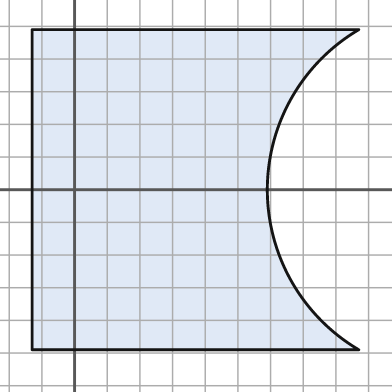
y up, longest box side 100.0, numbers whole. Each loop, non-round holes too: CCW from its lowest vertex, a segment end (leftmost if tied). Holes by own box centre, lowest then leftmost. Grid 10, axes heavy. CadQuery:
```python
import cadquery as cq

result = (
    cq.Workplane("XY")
    .moveTo(-13.0, -49.0)
    .lineTo(87.0, -49.0)
    .threePointArc((59.0, 0.0), (87.0, 49.0))
    .lineTo(-13.0, 49.0)
    .close()
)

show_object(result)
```